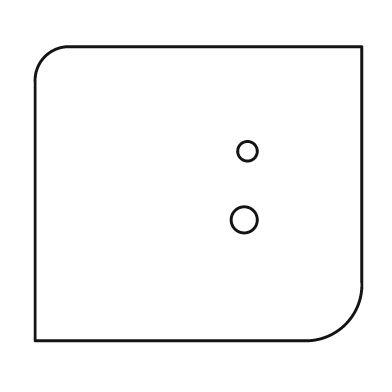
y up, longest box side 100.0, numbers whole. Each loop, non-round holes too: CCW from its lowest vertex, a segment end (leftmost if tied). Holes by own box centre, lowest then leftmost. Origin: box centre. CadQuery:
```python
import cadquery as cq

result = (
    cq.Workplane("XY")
    .moveTo(-50.0, -45.0)
    .lineTo(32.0, -45.0)
    .threePointArc((45.0, -40.0), (50.0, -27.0))
    .lineTo(50.0, 45.0)
    .lineTo(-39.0, 45.0)
    .threePointArc((-47.0, 42.0), (-50.0, 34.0))
    .close()
    .moveTo(14.0, -8.0)
    .circle(4.0)
    .moveTo(15.0, 13.0)
    .circle(3.0)
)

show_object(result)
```